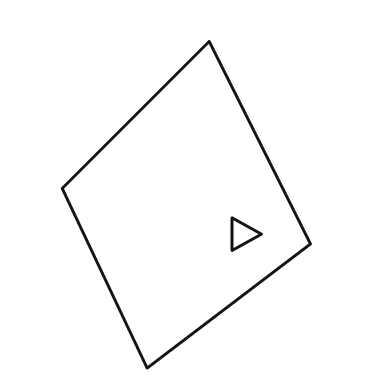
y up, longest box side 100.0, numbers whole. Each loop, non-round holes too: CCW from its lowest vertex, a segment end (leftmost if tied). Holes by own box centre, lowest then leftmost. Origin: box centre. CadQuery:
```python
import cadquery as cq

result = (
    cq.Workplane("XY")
    .moveTo(-12.0, -50.0)
    .lineTo(38.0, -12.0)
    .lineTo(7.0, 50.0)
    .lineTo(-38.0, 5.0)
    .close()
    .moveTo(14.0, -14.0)
    .lineTo(23.0, -9.0)
    .lineTo(14.0, -4.0)
    .close()
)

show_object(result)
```